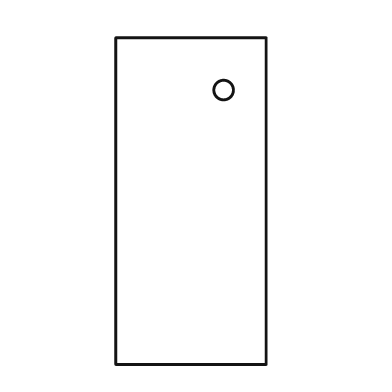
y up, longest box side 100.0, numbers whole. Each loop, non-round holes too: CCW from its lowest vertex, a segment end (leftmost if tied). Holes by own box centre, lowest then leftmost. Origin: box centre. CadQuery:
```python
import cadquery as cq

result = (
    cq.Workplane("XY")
    .moveTo(-23.0, -50.0)
    .lineTo(23.0, -50.0)
    .lineTo(23.0, 50.0)
    .lineTo(-23.0, 50.0)
    .close()
    .moveTo(10.0, 34.0)
    .circle(3.0)
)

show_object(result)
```